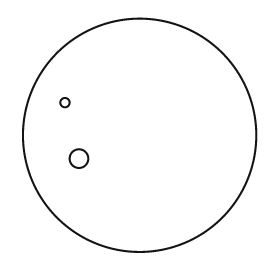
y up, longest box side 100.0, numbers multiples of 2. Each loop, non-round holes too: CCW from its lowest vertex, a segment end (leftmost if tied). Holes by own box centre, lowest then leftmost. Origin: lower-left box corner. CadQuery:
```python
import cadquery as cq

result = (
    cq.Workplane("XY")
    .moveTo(50.0, 50.0)
    .circle(50.0)
    .moveTo(24.0, 40.0)
    .circle(4.0)
    .moveTo(18.0, 64.0)
    .circle(2.0)
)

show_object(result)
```